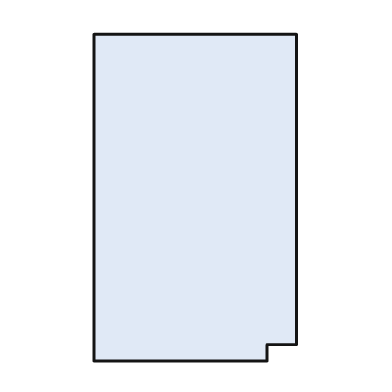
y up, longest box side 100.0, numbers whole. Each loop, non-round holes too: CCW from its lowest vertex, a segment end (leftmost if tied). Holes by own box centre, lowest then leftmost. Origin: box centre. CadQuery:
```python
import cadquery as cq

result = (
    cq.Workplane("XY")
    .moveTo(-31.0, -50.0)
    .lineTo(22.0, -50.0)
    .lineTo(22.0, -45.0)
    .lineTo(31.0, -45.0)
    .lineTo(31.0, 50.0)
    .lineTo(-31.0, 50.0)
    .close()
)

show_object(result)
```